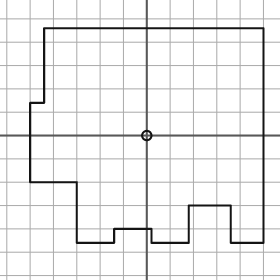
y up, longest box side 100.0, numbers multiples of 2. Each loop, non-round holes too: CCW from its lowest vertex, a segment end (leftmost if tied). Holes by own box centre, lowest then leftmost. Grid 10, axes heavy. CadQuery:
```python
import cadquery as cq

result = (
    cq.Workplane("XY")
    .moveTo(-30.0, -46.0)
    .lineTo(-14.0, -46.0)
    .lineTo(-14.0, -40.0)
    .lineTo(2.0, -40.0)
    .lineTo(2.0, -46.0)
    .lineTo(18.0, -46.0)
    .lineTo(18.0, -30.0)
    .lineTo(36.0, -30.0)
    .lineTo(36.0, -46.0)
    .lineTo(50.0, -46.0)
    .lineTo(50.0, 46.0)
    .lineTo(-44.0, 46.0)
    .lineTo(-44.0, 14.0)
    .lineTo(-50.0, 14.0)
    .lineTo(-50.0, -20.0)
    .lineTo(-30.0, -20.0)
    .close()
    .moveTo(0.0, 0.0)
    .circle(2.0)
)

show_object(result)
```